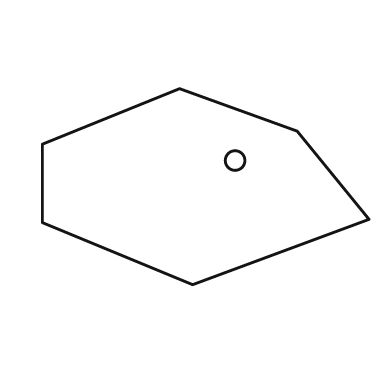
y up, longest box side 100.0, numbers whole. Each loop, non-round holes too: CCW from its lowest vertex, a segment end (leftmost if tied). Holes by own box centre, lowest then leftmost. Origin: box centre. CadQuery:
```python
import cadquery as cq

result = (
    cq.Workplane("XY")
    .moveTo(-4.0, -30.0)
    .lineTo(50.0, -10.0)
    .lineTo(28.0, 17.0)
    .lineTo(-8.0, 30.0)
    .lineTo(-50.0, 13.0)
    .lineTo(-50.0, -11.0)
    .close()
    .moveTo(9.0, 8.0)
    .circle(3.0)
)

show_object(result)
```